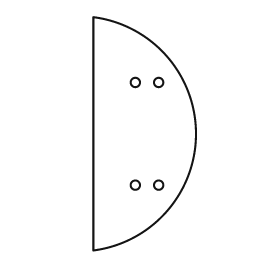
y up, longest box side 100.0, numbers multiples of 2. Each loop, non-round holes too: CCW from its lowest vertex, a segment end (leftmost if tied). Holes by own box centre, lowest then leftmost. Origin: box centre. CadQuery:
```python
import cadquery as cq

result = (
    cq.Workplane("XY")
    .moveTo(-22.0, -50.0)
    .threePointArc((22.0, 0.0), (-22.0, 50.0))
    .close()
    .moveTo(-4.0, -22.0)
    .circle(2.0)
    .moveTo(6.0, -22.0)
    .circle(2.0)
    .moveTo(-4.0, 22.0)
    .circle(2.0)
    .moveTo(6.0, 22.0)
    .circle(2.0)
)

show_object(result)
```